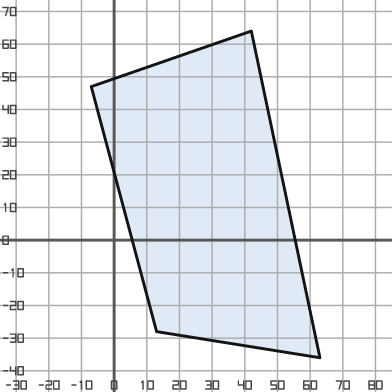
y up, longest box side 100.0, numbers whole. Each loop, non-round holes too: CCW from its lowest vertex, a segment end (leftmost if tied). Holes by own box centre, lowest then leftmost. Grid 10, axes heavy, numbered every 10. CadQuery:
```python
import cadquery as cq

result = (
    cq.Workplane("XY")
    .moveTo(63.0, -36.0)
    .lineTo(42.0, 64.0)
    .lineTo(-7.0, 47.0)
    .lineTo(13.0, -28.0)
    .close()
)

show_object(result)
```